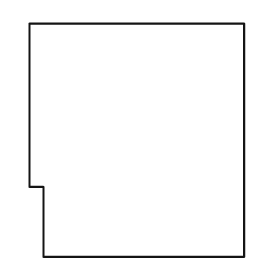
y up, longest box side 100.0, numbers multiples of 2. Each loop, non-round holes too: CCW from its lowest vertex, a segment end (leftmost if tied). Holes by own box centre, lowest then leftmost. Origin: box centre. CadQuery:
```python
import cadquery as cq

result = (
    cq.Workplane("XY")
    .moveTo(-40.0, -50.0)
    .lineTo(46.0, -50.0)
    .lineTo(46.0, 50.0)
    .lineTo(-46.0, 50.0)
    .lineTo(-46.0, -20.0)
    .lineTo(-40.0, -20.0)
    .close()
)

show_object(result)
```